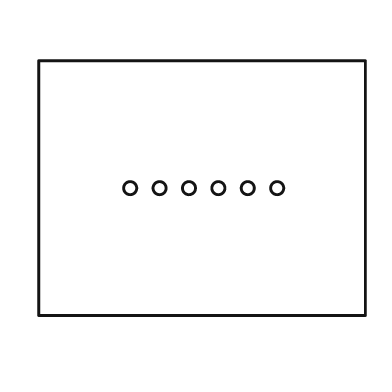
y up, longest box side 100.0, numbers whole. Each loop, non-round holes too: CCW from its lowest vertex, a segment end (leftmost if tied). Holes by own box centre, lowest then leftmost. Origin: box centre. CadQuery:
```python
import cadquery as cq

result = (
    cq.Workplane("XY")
    .moveTo(-50.0, -39.0)
    .lineTo(50.0, -39.0)
    .lineTo(50.0, 39.0)
    .lineTo(-50.0, 39.0)
    .close()
    .moveTo(-22.0, 0.0)
    .circle(2.0)
    .moveTo(-13.0, 0.0)
    .circle(2.0)
    .moveTo(-4.0, 0.0)
    .circle(2.0)
    .moveTo(5.0, 0.0)
    .circle(2.0)
    .moveTo(14.0, 0.0)
    .circle(2.0)
    .moveTo(23.0, 0.0)
    .circle(2.0)
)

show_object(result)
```